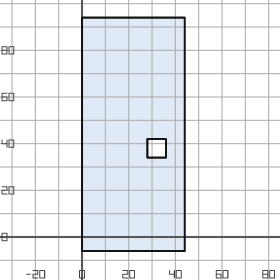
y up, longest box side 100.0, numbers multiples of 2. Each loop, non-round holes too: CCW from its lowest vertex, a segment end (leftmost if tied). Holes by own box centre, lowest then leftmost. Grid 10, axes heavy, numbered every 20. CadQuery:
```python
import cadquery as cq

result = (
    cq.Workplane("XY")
    .moveTo(0.0, -6.0)
    .lineTo(44.0, -6.0)
    .lineTo(44.0, 94.0)
    .lineTo(0.0, 94.0)
    .close()
    .moveTo(28.0, 34.0)
    .lineTo(36.0, 34.0)
    .lineTo(36.0, 42.0)
    .lineTo(28.0, 42.0)
    .close()
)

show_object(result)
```